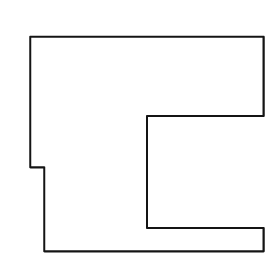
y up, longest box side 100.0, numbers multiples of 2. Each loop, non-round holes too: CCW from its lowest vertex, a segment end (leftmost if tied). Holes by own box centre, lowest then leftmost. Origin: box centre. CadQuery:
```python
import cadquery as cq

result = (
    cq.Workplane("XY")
    .moveTo(-44.0, -46.0)
    .lineTo(50.0, -46.0)
    .lineTo(50.0, -36.0)
    .lineTo(0.0, -36.0)
    .lineTo(0.0, 12.0)
    .lineTo(50.0, 12.0)
    .lineTo(50.0, 46.0)
    .lineTo(-50.0, 46.0)
    .lineTo(-50.0, -10.0)
    .lineTo(-44.0, -10.0)
    .close()
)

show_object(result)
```